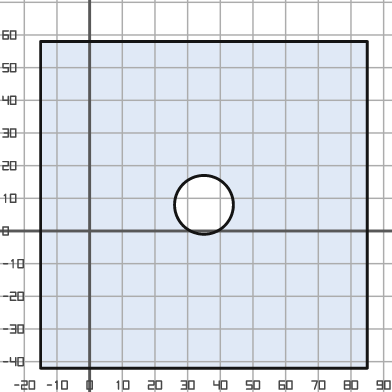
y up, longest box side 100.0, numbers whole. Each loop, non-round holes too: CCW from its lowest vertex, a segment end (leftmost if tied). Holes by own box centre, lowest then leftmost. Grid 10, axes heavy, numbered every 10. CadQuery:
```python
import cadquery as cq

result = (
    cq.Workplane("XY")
    .moveTo(-15.0, -42.0)
    .lineTo(85.0, -42.0)
    .lineTo(85.0, 58.0)
    .lineTo(-15.0, 58.0)
    .close()
    .moveTo(35.0, 8.0)
    .circle(9.0)
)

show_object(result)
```